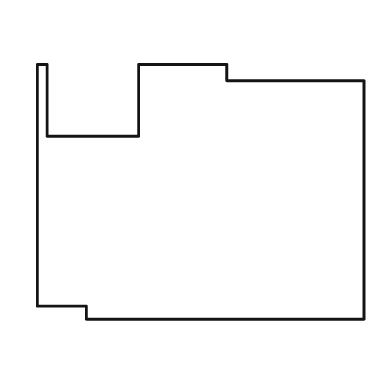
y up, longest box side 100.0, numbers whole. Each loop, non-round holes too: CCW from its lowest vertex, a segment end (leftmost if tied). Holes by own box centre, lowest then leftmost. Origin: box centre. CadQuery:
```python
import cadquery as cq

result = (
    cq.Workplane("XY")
    .moveTo(-35.0, -39.0)
    .lineTo(50.0, -39.0)
    .lineTo(50.0, 34.0)
    .lineTo(8.0, 34.0)
    .lineTo(8.0, 39.0)
    .lineTo(-19.0, 39.0)
    .lineTo(-19.0, 17.0)
    .lineTo(-47.0, 17.0)
    .lineTo(-47.0, 39.0)
    .lineTo(-50.0, 39.0)
    .lineTo(-50.0, -35.0)
    .lineTo(-35.0, -35.0)
    .close()
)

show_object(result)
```